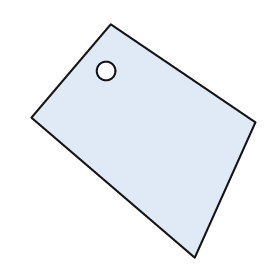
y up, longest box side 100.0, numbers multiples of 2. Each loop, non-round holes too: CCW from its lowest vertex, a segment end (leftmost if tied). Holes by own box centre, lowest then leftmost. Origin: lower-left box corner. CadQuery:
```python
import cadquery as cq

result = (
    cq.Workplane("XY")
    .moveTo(70.0, 0.0)
    .lineTo(96.0, 58.0)
    .lineTo(34.0, 100.0)
    .lineTo(0.0, 60.0)
    .close()
    .moveTo(32.0, 80.0)
    .circle(4.0)
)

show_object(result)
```